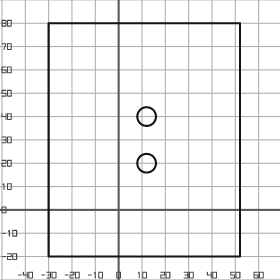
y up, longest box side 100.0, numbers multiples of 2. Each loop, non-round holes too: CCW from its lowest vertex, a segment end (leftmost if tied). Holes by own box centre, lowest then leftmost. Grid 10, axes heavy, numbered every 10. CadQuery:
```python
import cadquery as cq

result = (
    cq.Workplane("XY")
    .moveTo(-30.0, -20.0)
    .lineTo(52.0, -20.0)
    .lineTo(52.0, 80.0)
    .lineTo(-30.0, 80.0)
    .close()
    .moveTo(12.0, 20.0)
    .circle(4.0)
    .moveTo(12.0, 40.0)
    .circle(4.0)
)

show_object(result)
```